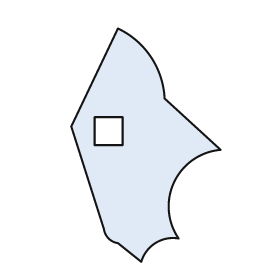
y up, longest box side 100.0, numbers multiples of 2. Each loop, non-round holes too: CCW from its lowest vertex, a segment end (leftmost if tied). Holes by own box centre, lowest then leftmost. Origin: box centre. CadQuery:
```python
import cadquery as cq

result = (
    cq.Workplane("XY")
    .moveTo(-2.0, -50.0)
    .threePointArc((4.0, -42.0), (14.0, -40.0))
    .threePointArc((12.0, -16.0), (32.0, -2.0))
    .lineTo(8.0, 20.0)
    .threePointArc((2.0, 38.0), (-12.0, 50.0))
    .lineTo(-32.0, 8.0)
    .lineTo(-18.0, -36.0)
    .threePointArc((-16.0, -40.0), (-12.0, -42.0))
    .close()
    .moveTo(-22.0, 0.0)
    .lineTo(-10.0, 0.0)
    .lineTo(-10.0, 12.0)
    .lineTo(-22.0, 12.0)
    .close()
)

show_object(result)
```